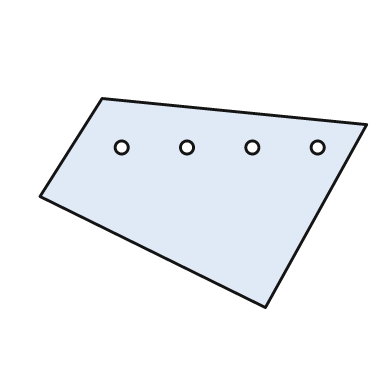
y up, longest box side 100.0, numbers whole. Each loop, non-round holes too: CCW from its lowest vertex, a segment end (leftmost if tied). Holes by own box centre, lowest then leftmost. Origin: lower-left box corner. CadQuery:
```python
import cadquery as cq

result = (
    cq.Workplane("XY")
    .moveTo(69.0, 0.0)
    .lineTo(100.0, 56.0)
    .lineTo(19.0, 64.0)
    .lineTo(0.0, 34.0)
    .close()
    .moveTo(25.0, 49.0)
    .circle(2.0)
    .moveTo(45.0, 49.0)
    .circle(2.0)
    .moveTo(65.0, 49.0)
    .circle(2.0)
    .moveTo(85.0, 49.0)
    .circle(2.0)
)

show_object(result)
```